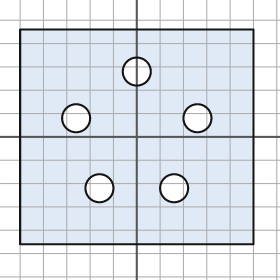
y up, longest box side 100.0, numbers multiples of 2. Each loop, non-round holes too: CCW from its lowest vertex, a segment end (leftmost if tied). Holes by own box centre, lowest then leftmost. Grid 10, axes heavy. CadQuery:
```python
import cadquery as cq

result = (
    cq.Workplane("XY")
    .moveTo(-50.0, -46.0)
    .lineTo(50.0, -46.0)
    .lineTo(50.0, 46.0)
    .lineTo(-50.0, 46.0)
    .close()
    .moveTo(-16.0, -22.0)
    .circle(6.0)
    .moveTo(16.0, -22.0)
    .circle(6.0)
    .moveTo(-26.0, 8.0)
    .circle(6.0)
    .moveTo(26.0, 8.0)
    .circle(6.0)
    .moveTo(0.0, 28.0)
    .circle(6.0)
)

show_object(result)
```